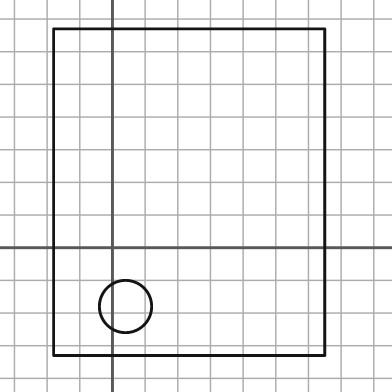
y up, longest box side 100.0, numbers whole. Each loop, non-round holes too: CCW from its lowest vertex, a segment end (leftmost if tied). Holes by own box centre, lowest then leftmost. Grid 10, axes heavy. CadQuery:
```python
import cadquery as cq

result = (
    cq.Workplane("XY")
    .moveTo(-18.0, -33.0)
    .lineTo(65.0, -33.0)
    .lineTo(65.0, 67.0)
    .lineTo(-18.0, 67.0)
    .close()
    .moveTo(4.0, -18.0)
    .circle(8.0)
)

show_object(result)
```